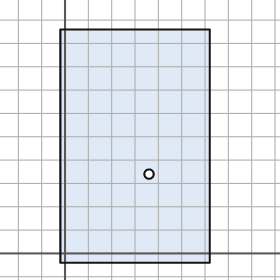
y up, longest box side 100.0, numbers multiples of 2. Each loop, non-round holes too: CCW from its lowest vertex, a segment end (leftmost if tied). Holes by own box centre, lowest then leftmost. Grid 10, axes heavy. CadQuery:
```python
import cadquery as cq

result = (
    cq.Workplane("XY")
    .moveTo(-2.0, -4.0)
    .lineTo(62.0, -4.0)
    .lineTo(62.0, 96.0)
    .lineTo(-2.0, 96.0)
    .close()
    .moveTo(36.0, 34.0)
    .circle(2.0)
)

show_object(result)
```